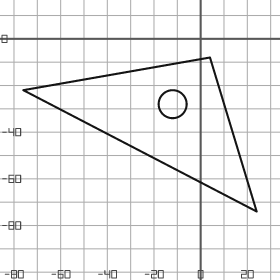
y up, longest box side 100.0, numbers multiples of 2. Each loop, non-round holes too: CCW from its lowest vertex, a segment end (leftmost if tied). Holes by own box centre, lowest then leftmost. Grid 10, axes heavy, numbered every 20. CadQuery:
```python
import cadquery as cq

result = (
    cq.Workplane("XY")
    .moveTo(24.0, -74.0)
    .lineTo(4.0, -8.0)
    .lineTo(-76.0, -22.0)
    .close()
    .moveTo(-12.0, -28.0)
    .circle(6.0)
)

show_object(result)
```